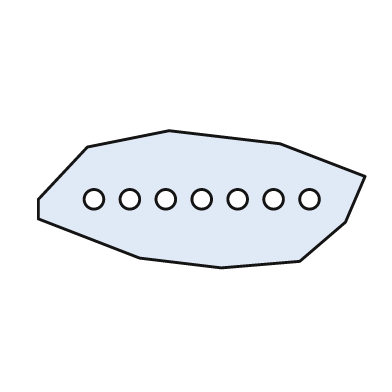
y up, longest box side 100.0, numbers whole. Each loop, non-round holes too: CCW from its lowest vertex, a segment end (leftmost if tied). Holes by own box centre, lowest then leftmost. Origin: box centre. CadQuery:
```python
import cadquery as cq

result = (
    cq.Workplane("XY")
    .moveTo(6.0, -21.0)
    .lineTo(30.0, -19.0)
    .lineTo(44.0, -7.0)
    .lineTo(50.0, 7.0)
    .lineTo(24.0, 17.0)
    .lineTo(-10.0, 21.0)
    .lineTo(-35.0, 16.0)
    .lineTo(-50.0, 0.0)
    .lineTo(-50.0, -6.0)
    .lineTo(-19.0, -18.0)
    .close()
    .moveTo(-33.0, 0.0)
    .circle(3.0)
    .moveTo(-22.0, 0.0)
    .circle(3.0)
    .moveTo(-11.0, 0.0)
    .circle(3.0)
    .moveTo(0.0, 0.0)
    .circle(3.0)
    .moveTo(11.0, 0.0)
    .circle(3.0)
    .moveTo(22.0, 0.0)
    .circle(3.0)
    .moveTo(33.0, 0.0)
    .circle(3.0)
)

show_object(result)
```